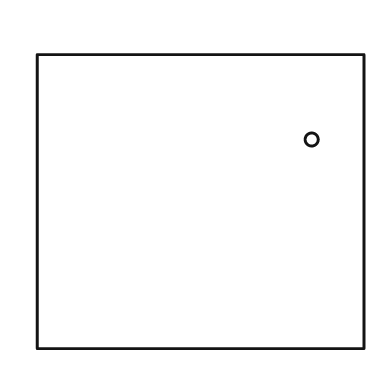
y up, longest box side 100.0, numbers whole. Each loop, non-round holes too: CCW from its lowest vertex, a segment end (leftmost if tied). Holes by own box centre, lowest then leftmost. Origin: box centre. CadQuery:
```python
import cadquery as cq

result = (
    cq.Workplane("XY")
    .moveTo(-50.0, -45.0)
    .lineTo(50.0, -45.0)
    .lineTo(50.0, 45.0)
    .lineTo(-50.0, 45.0)
    .close()
    .moveTo(34.0, 19.0)
    .circle(2.0)
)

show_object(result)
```